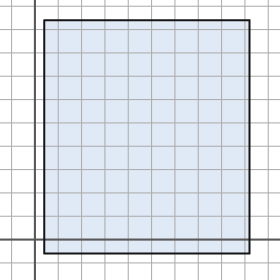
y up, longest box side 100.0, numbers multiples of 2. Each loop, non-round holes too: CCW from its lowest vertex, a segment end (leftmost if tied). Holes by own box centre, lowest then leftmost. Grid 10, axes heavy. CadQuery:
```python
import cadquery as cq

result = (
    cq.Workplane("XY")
    .moveTo(4.0, -6.0)
    .lineTo(92.0, -6.0)
    .lineTo(92.0, 94.0)
    .lineTo(4.0, 94.0)
    .close()
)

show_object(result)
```